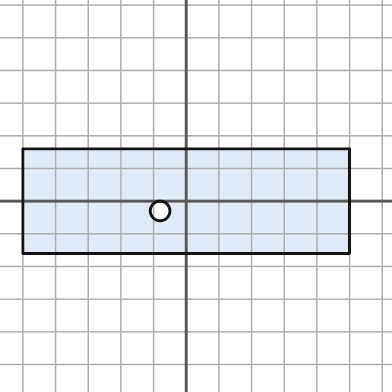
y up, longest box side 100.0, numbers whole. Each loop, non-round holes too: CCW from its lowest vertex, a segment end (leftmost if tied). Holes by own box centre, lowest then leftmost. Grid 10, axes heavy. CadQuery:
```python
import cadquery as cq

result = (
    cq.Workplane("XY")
    .moveTo(-50.0, -16.0)
    .lineTo(50.0, -16.0)
    .lineTo(50.0, 16.0)
    .lineTo(-50.0, 16.0)
    .close()
    .moveTo(-8.0, -3.0)
    .circle(3.0)
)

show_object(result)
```